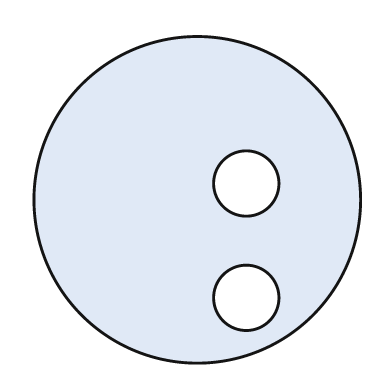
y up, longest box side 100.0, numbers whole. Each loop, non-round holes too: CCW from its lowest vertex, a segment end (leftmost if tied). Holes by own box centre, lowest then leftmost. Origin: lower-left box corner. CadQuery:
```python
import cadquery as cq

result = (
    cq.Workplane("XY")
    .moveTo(50.0, 50.0)
    .circle(50.0)
    .moveTo(65.0, 20.0)
    .circle(10.0)
    .moveTo(65.0, 55.0)
    .circle(10.0)
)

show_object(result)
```